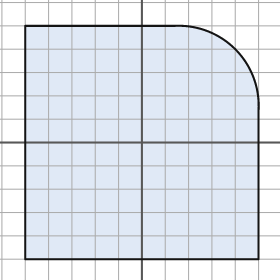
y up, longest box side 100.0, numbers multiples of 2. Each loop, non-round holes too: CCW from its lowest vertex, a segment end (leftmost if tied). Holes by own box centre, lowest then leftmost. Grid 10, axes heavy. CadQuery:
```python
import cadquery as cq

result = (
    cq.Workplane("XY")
    .moveTo(-50.0, -50.0)
    .lineTo(50.0, -50.0)
    .lineTo(50.0, 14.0)
    .threePointArc((40.0, 40.0), (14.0, 50.0))
    .lineTo(-50.0, 50.0)
    .close()
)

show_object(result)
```